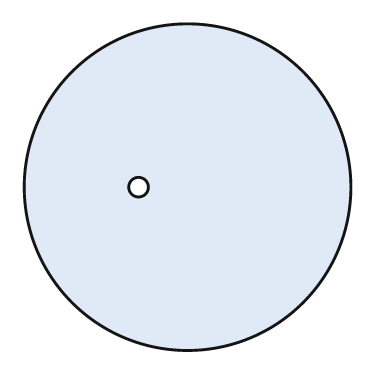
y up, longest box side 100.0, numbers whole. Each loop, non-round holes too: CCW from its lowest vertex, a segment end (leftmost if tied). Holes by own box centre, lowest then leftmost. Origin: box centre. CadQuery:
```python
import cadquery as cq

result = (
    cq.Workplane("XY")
    .moveTo(0.0, 0.0)
    .circle(50.0)
    .moveTo(-15.0, 0.0)
    .circle(3.0)
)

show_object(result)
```